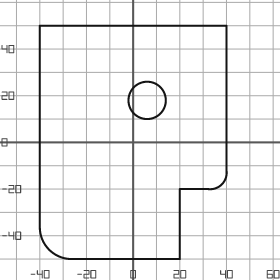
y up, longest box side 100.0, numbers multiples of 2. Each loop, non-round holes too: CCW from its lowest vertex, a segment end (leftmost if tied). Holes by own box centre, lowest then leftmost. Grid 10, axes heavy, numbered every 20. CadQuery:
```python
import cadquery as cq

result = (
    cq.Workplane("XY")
    .moveTo(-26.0, -50.0)
    .lineTo(20.0, -50.0)
    .lineTo(20.0, -20.0)
    .lineTo(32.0, -20.0)
    .threePointArc((38.0, -18.0), (40.0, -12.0))
    .lineTo(40.0, 50.0)
    .lineTo(-40.0, 50.0)
    .lineTo(-40.0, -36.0)
    .threePointArc((-36.0, -46.0), (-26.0, -50.0))
    .close()
    .moveTo(6.0, 18.0)
    .circle(8.0)
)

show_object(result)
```